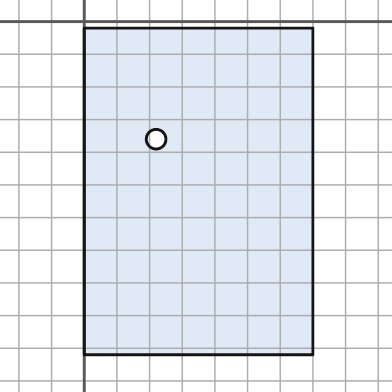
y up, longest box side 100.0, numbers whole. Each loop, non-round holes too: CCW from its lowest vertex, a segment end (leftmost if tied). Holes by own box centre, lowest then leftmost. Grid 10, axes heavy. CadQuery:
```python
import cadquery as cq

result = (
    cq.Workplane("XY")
    .moveTo(0.0, -102.0)
    .lineTo(70.0, -102.0)
    .lineTo(70.0, -2.0)
    .lineTo(0.0, -2.0)
    .close()
    .moveTo(22.0, -36.0)
    .circle(3.0)
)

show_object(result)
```